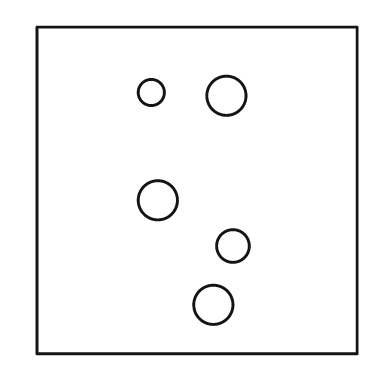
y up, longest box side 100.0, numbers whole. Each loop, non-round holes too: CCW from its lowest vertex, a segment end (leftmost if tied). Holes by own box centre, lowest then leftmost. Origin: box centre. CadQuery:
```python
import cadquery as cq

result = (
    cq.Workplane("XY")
    .moveTo(-49.0, -50.0)
    .lineTo(49.0, -50.0)
    .lineTo(49.0, 50.0)
    .lineTo(-49.0, 50.0)
    .close()
    .moveTo(5.0, -35.0)
    .circle(6.0)
    .moveTo(11.0, -17.0)
    .circle(5.0)
    .moveTo(-12.0, -3.0)
    .circle(6.0)
    .moveTo(9.0, 29.0)
    .circle(6.0)
    .moveTo(-14.0, 30.0)
    .circle(4.0)
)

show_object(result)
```